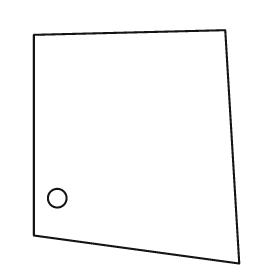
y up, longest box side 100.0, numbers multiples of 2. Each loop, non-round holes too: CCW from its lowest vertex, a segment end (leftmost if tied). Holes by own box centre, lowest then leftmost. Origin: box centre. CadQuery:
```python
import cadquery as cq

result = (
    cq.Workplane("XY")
    .moveTo(44.0, -50.0)
    .lineTo(38.0, 50.0)
    .lineTo(-44.0, 48.0)
    .lineTo(-44.0, -38.0)
    .close()
    .moveTo(-34.0, -22.0)
    .circle(4.0)
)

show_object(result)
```